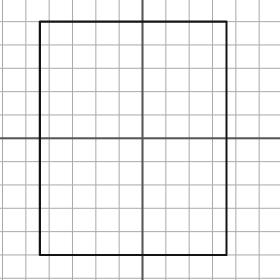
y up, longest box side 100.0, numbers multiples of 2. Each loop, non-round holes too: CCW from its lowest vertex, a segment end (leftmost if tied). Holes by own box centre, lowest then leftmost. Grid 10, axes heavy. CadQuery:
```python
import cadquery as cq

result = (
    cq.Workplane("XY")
    .moveTo(-44.0, -50.0)
    .lineTo(36.0, -50.0)
    .lineTo(36.0, 50.0)
    .lineTo(-44.0, 50.0)
    .close()
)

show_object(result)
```